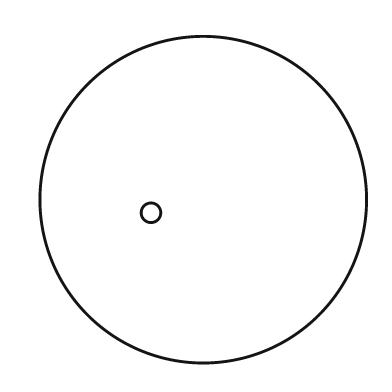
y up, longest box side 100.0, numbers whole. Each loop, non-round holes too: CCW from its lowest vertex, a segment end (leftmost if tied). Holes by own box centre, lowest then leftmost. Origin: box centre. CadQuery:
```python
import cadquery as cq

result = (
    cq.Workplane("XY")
    .moveTo(0.0, 0.0)
    .circle(50.0)
    .moveTo(-16.0, -4.0)
    .circle(3.0)
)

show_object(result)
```